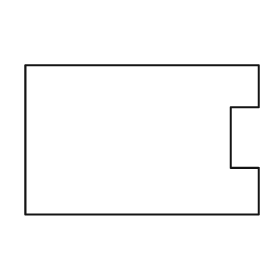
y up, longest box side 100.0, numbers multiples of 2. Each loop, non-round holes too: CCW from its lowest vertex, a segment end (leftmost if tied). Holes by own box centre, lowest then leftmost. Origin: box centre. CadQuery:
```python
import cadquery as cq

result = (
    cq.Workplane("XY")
    .moveTo(-50.0, -32.0)
    .lineTo(50.0, -32.0)
    .lineTo(50.0, -12.0)
    .lineTo(38.0, -12.0)
    .lineTo(38.0, 14.0)
    .lineTo(50.0, 14.0)
    .lineTo(50.0, 32.0)
    .lineTo(-50.0, 32.0)
    .close()
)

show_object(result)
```